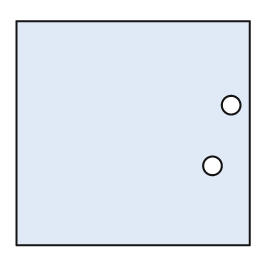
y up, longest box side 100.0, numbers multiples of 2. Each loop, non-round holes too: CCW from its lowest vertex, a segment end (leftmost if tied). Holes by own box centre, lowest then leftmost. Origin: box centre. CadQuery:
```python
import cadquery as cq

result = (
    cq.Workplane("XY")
    .moveTo(-50.0, -48.0)
    .lineTo(50.0, -48.0)
    .lineTo(50.0, 48.0)
    .lineTo(-50.0, 48.0)
    .close()
    .moveTo(34.0, -14.0)
    .circle(4.0)
    .moveTo(42.0, 12.0)
    .circle(4.0)
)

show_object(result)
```